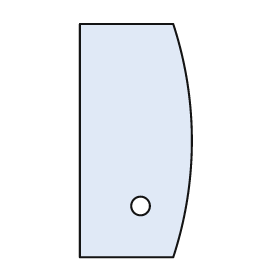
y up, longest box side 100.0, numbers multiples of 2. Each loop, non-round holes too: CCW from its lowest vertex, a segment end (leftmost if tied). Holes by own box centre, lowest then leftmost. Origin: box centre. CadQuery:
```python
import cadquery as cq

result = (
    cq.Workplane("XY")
    .moveTo(-24.0, -50.0)
    .lineTo(16.0, -50.0)
    .threePointArc((24.0, 0.0), (16.0, 50.0))
    .lineTo(-24.0, 50.0)
    .close()
    .moveTo(2.0, -28.0)
    .circle(4.0)
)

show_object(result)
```